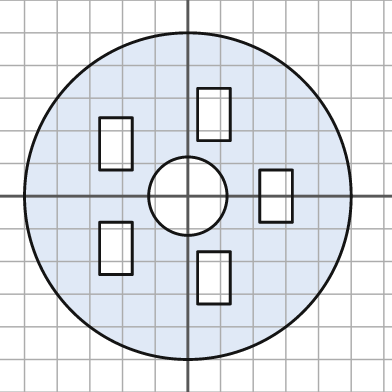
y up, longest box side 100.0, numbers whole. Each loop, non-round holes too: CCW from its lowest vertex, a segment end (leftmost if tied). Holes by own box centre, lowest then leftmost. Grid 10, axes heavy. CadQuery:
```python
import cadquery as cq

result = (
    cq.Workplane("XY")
    .moveTo(0.0, 0.0)
    .circle(50.0)
    .moveTo(3.0, -33.0)
    .lineTo(13.0, -33.0)
    .lineTo(13.0, -17.0)
    .lineTo(3.0, -17.0)
    .close()
    .moveTo(-27.0, -24.0)
    .lineTo(-17.0, -24.0)
    .lineTo(-17.0, -8.0)
    .lineTo(-27.0, -8.0)
    .close()
    .moveTo(0.0, 0.0)
    .circle(12.0)
    .moveTo(22.0, -8.0)
    .lineTo(32.0, -8.0)
    .lineTo(32.0, 8.0)
    .lineTo(22.0, 8.0)
    .close()
    .moveTo(-27.0, 8.0)
    .lineTo(-17.0, 8.0)
    .lineTo(-17.0, 24.0)
    .lineTo(-27.0, 24.0)
    .close()
    .moveTo(3.0, 17.0)
    .lineTo(13.0, 17.0)
    .lineTo(13.0, 33.0)
    .lineTo(3.0, 33.0)
    .close()
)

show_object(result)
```